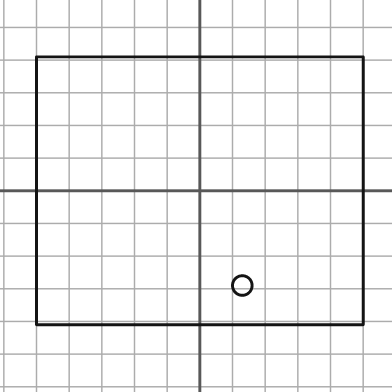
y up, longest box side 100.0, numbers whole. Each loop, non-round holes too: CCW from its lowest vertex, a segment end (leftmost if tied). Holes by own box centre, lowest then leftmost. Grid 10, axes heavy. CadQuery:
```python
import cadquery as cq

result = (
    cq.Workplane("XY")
    .moveTo(-50.0, -41.0)
    .lineTo(50.0, -41.0)
    .lineTo(50.0, 41.0)
    .lineTo(-50.0, 41.0)
    .close()
    .moveTo(13.0, -29.0)
    .circle(3.0)
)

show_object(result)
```